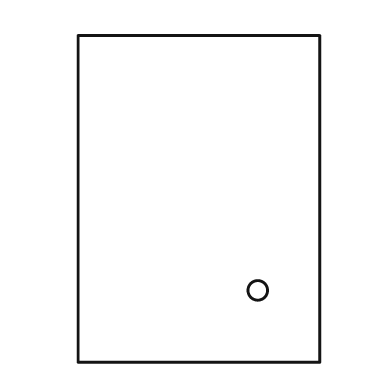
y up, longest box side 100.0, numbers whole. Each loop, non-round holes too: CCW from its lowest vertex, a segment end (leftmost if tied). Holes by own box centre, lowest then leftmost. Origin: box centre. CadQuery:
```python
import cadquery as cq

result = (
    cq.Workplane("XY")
    .moveTo(-37.0, -50.0)
    .lineTo(37.0, -50.0)
    .lineTo(37.0, 50.0)
    .lineTo(-37.0, 50.0)
    .close()
    .moveTo(18.0, -28.0)
    .circle(3.0)
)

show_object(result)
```